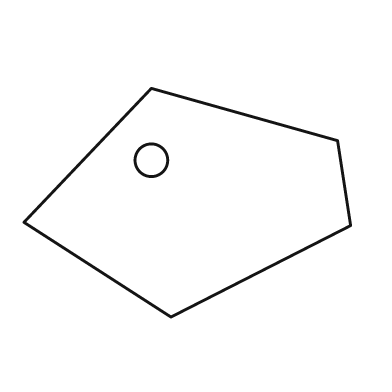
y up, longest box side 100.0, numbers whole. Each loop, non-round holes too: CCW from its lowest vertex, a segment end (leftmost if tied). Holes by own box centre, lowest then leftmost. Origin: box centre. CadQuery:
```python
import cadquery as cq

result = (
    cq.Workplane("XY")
    .moveTo(-5.0, -35.0)
    .lineTo(50.0, -7.0)
    .lineTo(46.0, 19.0)
    .lineTo(-11.0, 35.0)
    .lineTo(-50.0, -6.0)
    .close()
    .moveTo(-11.0, 13.0)
    .circle(5.0)
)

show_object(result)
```